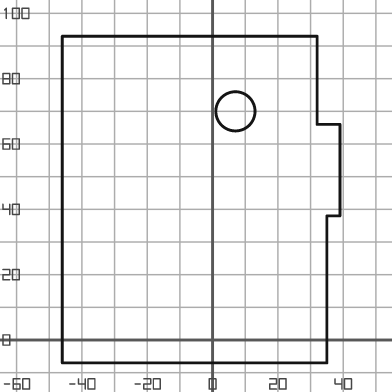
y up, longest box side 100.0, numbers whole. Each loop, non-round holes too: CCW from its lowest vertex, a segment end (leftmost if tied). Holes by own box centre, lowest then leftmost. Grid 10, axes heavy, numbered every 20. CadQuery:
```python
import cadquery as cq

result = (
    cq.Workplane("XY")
    .moveTo(-46.0, -7.0)
    .lineTo(35.0, -7.0)
    .lineTo(35.0, 38.0)
    .lineTo(39.0, 38.0)
    .lineTo(39.0, 66.0)
    .lineTo(32.0, 66.0)
    .lineTo(32.0, 93.0)
    .lineTo(-46.0, 93.0)
    .close()
    .moveTo(7.0, 70.0)
    .circle(6.0)
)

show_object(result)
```